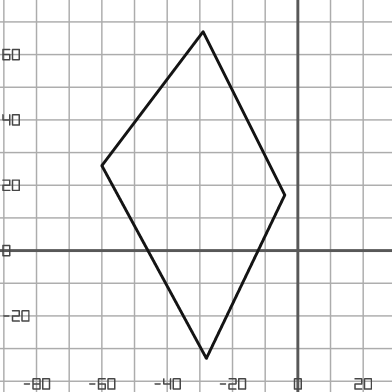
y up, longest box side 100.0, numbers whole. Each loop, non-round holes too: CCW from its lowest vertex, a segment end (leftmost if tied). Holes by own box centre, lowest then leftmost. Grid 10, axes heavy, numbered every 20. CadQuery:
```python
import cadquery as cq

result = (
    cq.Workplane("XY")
    .moveTo(-28.0, -33.0)
    .lineTo(-4.0, 17.0)
    .lineTo(-29.0, 67.0)
    .lineTo(-60.0, 26.0)
    .close()
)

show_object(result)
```